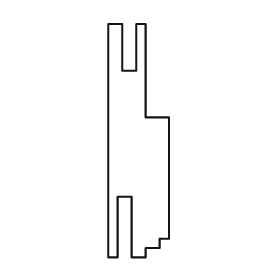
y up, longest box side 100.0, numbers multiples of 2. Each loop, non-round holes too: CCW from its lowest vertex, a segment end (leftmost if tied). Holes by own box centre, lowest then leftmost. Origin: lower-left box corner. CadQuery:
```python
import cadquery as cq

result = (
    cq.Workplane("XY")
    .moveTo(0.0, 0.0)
    .lineTo(4.0, 0.0)
    .lineTo(4.0, 26.0)
    .lineTo(10.0, 26.0)
    .lineTo(10.0, 0.0)
    .lineTo(16.0, 0.0)
    .lineTo(16.0, 4.0)
    .lineTo(22.0, 4.0)
    .lineTo(22.0, 8.0)
    .lineTo(26.0, 8.0)
    .lineTo(26.0, 60.0)
    .lineTo(16.0, 60.0)
    .lineTo(16.0, 100.0)
    .lineTo(12.0, 100.0)
    .lineTo(12.0, 80.0)
    .lineTo(6.0, 80.0)
    .lineTo(6.0, 100.0)
    .lineTo(0.0, 100.0)
    .close()
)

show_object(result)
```